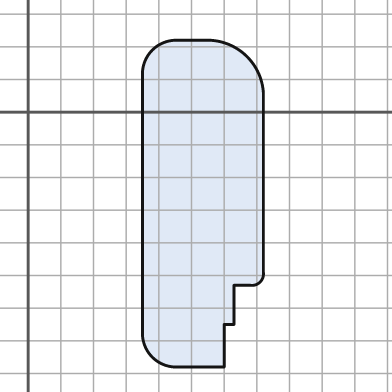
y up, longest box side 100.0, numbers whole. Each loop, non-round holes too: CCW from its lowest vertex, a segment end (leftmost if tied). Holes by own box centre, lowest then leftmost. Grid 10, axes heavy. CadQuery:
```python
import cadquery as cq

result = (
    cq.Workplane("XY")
    .moveTo(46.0, -78.0)
    .lineTo(60.0, -78.0)
    .lineTo(60.0, -65.0)
    .lineTo(63.0, -65.0)
    .lineTo(63.0, -53.0)
    .lineTo(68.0, -53.0)
    .threePointArc((71.0, -52.0), (72.0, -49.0))
    .lineTo(72.0, 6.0)
    .threePointArc((67.0, 17.0), (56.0, 22.0))
    .lineTo(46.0, 22.0)
    .threePointArc((38.0, 19.0), (35.0, 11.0))
    .lineTo(35.0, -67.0)
    .threePointArc((38.0, -75.0), (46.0, -78.0))
    .close()
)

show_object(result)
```